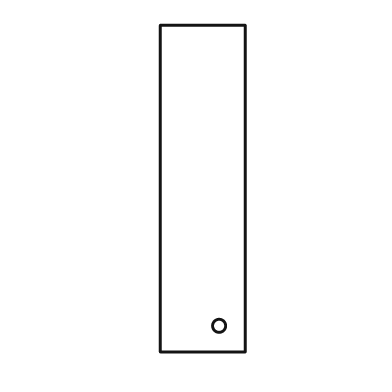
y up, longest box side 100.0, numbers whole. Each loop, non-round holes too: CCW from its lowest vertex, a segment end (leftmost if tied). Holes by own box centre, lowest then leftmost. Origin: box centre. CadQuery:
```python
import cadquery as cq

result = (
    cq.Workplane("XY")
    .moveTo(-13.0, -50.0)
    .lineTo(13.0, -50.0)
    .lineTo(13.0, 50.0)
    .lineTo(-13.0, 50.0)
    .close()
    .moveTo(5.0, -42.0)
    .circle(2.0)
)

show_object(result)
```